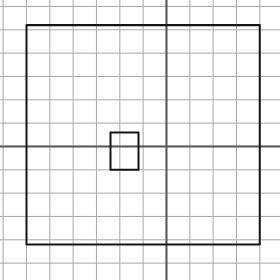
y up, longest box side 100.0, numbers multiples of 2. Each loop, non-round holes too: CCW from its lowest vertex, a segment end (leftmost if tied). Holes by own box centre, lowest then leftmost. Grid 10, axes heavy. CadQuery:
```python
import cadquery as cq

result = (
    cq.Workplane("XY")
    .moveTo(-60.0, -42.0)
    .lineTo(40.0, -42.0)
    .lineTo(40.0, 52.0)
    .lineTo(-60.0, 52.0)
    .close()
    .moveTo(-24.0, -10.0)
    .lineTo(-12.0, -10.0)
    .lineTo(-12.0, 6.0)
    .lineTo(-24.0, 6.0)
    .close()
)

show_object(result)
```